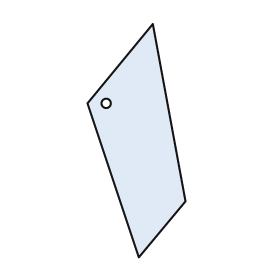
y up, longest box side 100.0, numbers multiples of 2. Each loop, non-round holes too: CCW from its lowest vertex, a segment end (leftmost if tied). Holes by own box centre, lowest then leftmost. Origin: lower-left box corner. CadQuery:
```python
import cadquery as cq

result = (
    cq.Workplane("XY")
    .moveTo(22.0, 0.0)
    .lineTo(42.0, 24.0)
    .lineTo(28.0, 100.0)
    .lineTo(0.0, 66.0)
    .close()
    .moveTo(8.0, 66.0)
    .circle(2.0)
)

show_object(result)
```